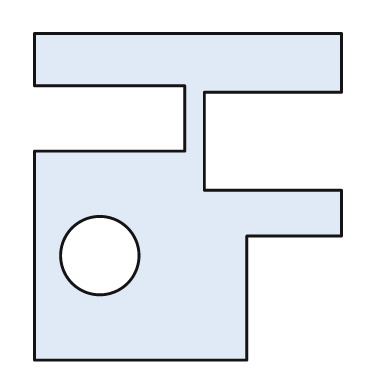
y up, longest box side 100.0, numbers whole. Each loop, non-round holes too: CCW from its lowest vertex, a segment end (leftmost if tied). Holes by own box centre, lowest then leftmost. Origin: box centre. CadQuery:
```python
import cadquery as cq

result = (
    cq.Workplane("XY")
    .moveTo(-47.0, -50.0)
    .lineTo(18.0, -50.0)
    .lineTo(18.0, -12.0)
    .lineTo(47.0, -12.0)
    .lineTo(47.0, 2.0)
    .lineTo(5.0, 2.0)
    .lineTo(5.0, 32.0)
    .lineTo(47.0, 32.0)
    .lineTo(47.0, 50.0)
    .lineTo(-47.0, 50.0)
    .lineTo(-47.0, 34.0)
    .lineTo(-1.0, 34.0)
    .lineTo(-1.0, 14.0)
    .lineTo(-47.0, 14.0)
    .close()
    .moveTo(-27.0, -18.0)
    .circle(12.0)
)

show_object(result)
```